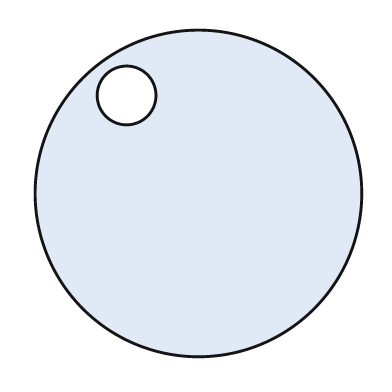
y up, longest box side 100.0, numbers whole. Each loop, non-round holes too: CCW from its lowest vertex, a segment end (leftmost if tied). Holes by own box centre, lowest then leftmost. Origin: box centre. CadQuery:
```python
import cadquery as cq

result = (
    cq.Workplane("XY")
    .moveTo(0.0, 0.0)
    .circle(50.0)
    .moveTo(-22.0, 30.0)
    .circle(9.0)
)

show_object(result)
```